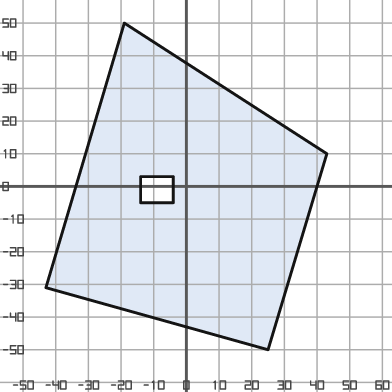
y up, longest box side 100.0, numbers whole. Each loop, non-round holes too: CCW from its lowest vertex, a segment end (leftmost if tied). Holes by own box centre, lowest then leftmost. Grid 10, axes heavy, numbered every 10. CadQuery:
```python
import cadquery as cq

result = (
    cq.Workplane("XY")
    .moveTo(25.0, -50.0)
    .lineTo(43.0, 10.0)
    .lineTo(-19.0, 50.0)
    .lineTo(-43.0, -31.0)
    .close()
    .moveTo(-14.0, -5.0)
    .lineTo(-4.0, -5.0)
    .lineTo(-4.0, 3.0)
    .lineTo(-14.0, 3.0)
    .close()
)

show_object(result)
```